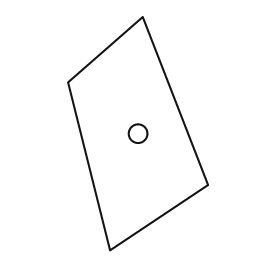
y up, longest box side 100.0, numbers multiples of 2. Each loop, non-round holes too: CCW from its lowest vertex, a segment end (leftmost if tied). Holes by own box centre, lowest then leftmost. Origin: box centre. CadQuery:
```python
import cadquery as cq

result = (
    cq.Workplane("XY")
    .moveTo(-12.0, -50.0)
    .lineTo(30.0, -22.0)
    .lineTo(2.0, 50.0)
    .lineTo(-30.0, 22.0)
    .close()
    .moveTo(0.0, 0.0)
    .circle(4.0)
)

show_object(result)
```